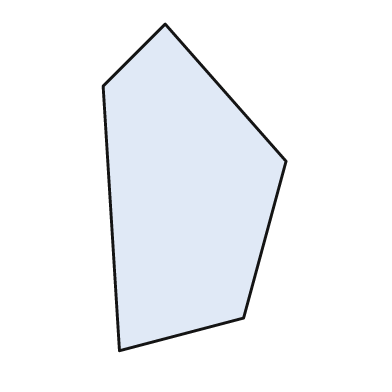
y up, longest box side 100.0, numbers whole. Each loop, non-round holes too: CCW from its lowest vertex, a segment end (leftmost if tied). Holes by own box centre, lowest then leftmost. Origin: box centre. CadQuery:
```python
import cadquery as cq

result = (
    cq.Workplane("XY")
    .moveTo(-23.0, -50.0)
    .lineTo(15.0, -40.0)
    .lineTo(28.0, 8.0)
    .lineTo(-9.0, 50.0)
    .lineTo(-28.0, 31.0)
    .close()
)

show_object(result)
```